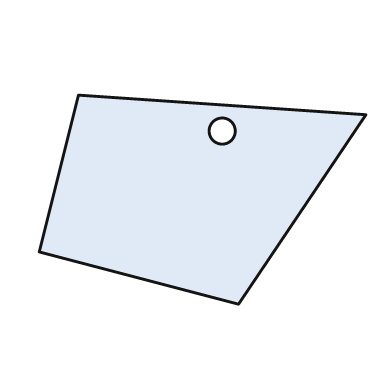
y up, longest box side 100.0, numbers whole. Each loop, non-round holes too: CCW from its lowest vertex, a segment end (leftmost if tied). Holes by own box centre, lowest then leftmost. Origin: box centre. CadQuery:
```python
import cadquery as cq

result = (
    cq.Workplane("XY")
    .moveTo(11.0, -32.0)
    .lineTo(50.0, 26.0)
    .lineTo(-38.0, 32.0)
    .lineTo(-50.0, -16.0)
    .close()
    .moveTo(6.0, 21.0)
    .circle(4.0)
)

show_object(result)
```